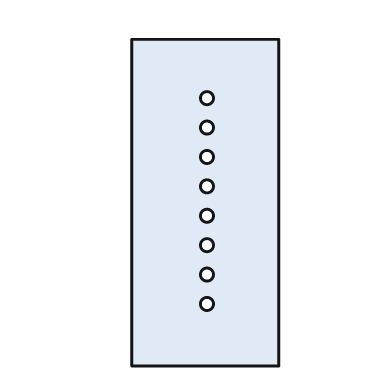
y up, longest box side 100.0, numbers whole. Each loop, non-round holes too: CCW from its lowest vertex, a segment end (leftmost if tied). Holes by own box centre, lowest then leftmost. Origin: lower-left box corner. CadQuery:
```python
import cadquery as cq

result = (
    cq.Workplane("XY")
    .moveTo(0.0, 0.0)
    .lineTo(45.0, 0.0)
    .lineTo(45.0, 100.0)
    .lineTo(0.0, 100.0)
    .close()
    .moveTo(23.0, 19.0)
    .circle(2.0)
    .moveTo(23.0, 28.0)
    .circle(2.0)
    .moveTo(23.0, 37.0)
    .circle(2.0)
    .moveTo(23.0, 46.0)
    .circle(2.0)
    .moveTo(23.0, 55.0)
    .circle(2.0)
    .moveTo(23.0, 64.0)
    .circle(2.0)
    .moveTo(23.0, 73.0)
    .circle(2.0)
    .moveTo(23.0, 82.0)
    .circle(2.0)
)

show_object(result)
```